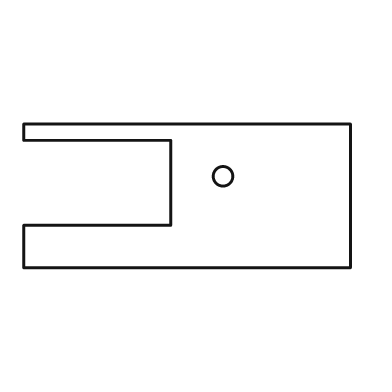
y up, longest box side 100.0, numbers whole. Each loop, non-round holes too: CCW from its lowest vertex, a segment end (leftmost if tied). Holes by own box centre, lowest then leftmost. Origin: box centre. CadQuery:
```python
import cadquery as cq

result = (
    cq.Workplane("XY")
    .moveTo(-50.0, -22.0)
    .lineTo(50.0, -22.0)
    .lineTo(50.0, 22.0)
    .lineTo(-50.0, 22.0)
    .lineTo(-50.0, 17.0)
    .lineTo(-5.0, 17.0)
    .lineTo(-5.0, -9.0)
    .lineTo(-50.0, -9.0)
    .close()
    .moveTo(11.0, 6.0)
    .circle(3.0)
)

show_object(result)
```